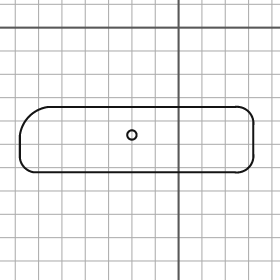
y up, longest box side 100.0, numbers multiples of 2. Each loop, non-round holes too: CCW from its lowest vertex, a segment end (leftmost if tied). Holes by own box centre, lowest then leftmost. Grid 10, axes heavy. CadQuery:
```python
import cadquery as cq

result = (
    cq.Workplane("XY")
    .moveTo(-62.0, -62.0)
    .lineTo(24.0, -62.0)
    .threePointArc((30.0, -60.0), (32.0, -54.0))
    .lineTo(32.0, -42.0)
    .threePointArc((30.0, -36.0), (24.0, -34.0))
    .lineTo(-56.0, -34.0)
    .threePointArc((-64.0, -38.0), (-68.0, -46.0))
    .lineTo(-68.0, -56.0)
    .threePointArc((-66.0, -60.0), (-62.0, -62.0))
    .close()
    .moveTo(-20.0, -46.0)
    .circle(2.0)
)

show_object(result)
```